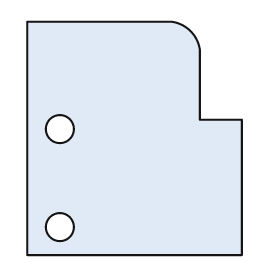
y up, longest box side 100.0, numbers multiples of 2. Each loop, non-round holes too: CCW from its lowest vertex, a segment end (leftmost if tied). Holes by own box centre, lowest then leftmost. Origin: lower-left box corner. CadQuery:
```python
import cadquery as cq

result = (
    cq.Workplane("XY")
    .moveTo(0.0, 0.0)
    .lineTo(92.0, 0.0)
    .lineTo(92.0, 58.0)
    .lineTo(74.0, 58.0)
    .lineTo(74.0, 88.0)
    .threePointArc((70.0, 96.0), (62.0, 100.0))
    .lineTo(0.0, 100.0)
    .close()
    .moveTo(14.0, 12.0)
    .circle(6.0)
    .moveTo(14.0, 54.0)
    .circle(6.0)
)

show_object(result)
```